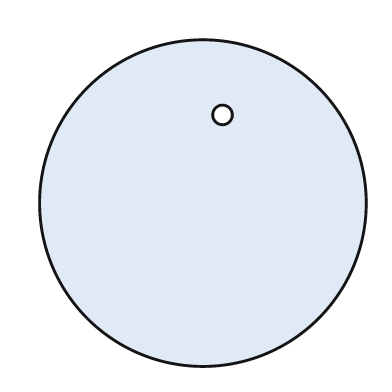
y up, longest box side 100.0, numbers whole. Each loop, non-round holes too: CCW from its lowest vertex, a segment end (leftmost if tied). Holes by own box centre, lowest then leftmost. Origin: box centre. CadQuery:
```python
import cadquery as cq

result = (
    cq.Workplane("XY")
    .moveTo(0.0, 0.0)
    .circle(50.0)
    .moveTo(6.0, 27.0)
    .circle(3.0)
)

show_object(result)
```